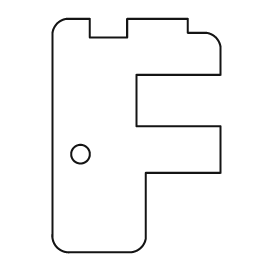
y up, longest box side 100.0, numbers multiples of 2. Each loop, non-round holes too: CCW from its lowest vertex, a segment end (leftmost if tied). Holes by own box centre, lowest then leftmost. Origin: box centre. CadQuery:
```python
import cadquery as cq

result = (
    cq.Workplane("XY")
    .moveTo(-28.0, -50.0)
    .lineTo(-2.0, -50.0)
    .threePointArc((2.0, -48.0), (4.0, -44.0))
    .lineTo(4.0, -16.0)
    .lineTo(36.0, -16.0)
    .lineTo(36.0, 4.0)
    .lineTo(0.0, 4.0)
    .lineTo(0.0, 26.0)
    .lineTo(36.0, 26.0)
    .lineTo(36.0, 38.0)
    .threePointArc((34.0, 42.0), (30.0, 44.0))
    .lineTo(22.0, 44.0)
    .lineTo(22.0, 50.0)
    .lineTo(-4.0, 50.0)
    .lineTo(-4.0, 42.0)
    .lineTo(-20.0, 42.0)
    .lineTo(-20.0, 50.0)
    .lineTo(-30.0, 50.0)
    .threePointArc((-34.0, 48.0), (-36.0, 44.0))
    .lineTo(-36.0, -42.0)
    .threePointArc((-34.0, -48.0), (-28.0, -50.0))
    .close()
    .moveTo(-24.0, -8.0)
    .circle(4.0)
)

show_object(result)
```